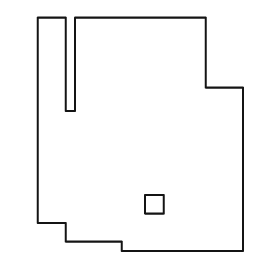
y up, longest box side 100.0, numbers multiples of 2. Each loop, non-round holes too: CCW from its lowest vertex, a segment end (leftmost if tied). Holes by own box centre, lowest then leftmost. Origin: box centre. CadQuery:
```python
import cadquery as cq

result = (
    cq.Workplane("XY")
    .moveTo(-8.0, -50.0)
    .lineTo(44.0, -50.0)
    .lineTo(44.0, 20.0)
    .lineTo(28.0, 20.0)
    .lineTo(28.0, 50.0)
    .lineTo(-28.0, 50.0)
    .lineTo(-28.0, 10.0)
    .lineTo(-32.0, 10.0)
    .lineTo(-32.0, 50.0)
    .lineTo(-44.0, 50.0)
    .lineTo(-44.0, -38.0)
    .lineTo(-32.0, -38.0)
    .lineTo(-32.0, -46.0)
    .lineTo(-8.0, -46.0)
    .close()
    .moveTo(2.0, -34.0)
    .lineTo(10.0, -34.0)
    .lineTo(10.0, -26.0)
    .lineTo(2.0, -26.0)
    .close()
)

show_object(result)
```